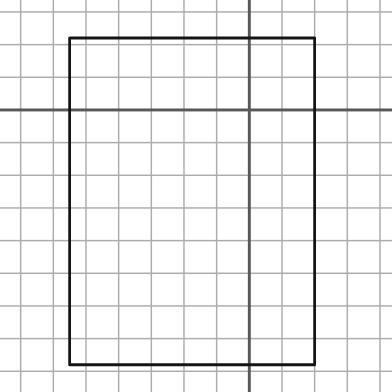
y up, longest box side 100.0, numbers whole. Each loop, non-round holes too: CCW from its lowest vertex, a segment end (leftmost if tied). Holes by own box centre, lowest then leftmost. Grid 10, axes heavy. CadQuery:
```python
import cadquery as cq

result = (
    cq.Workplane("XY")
    .moveTo(-55.0, -78.0)
    .lineTo(20.0, -78.0)
    .lineTo(20.0, 22.0)
    .lineTo(-55.0, 22.0)
    .close()
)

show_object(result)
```